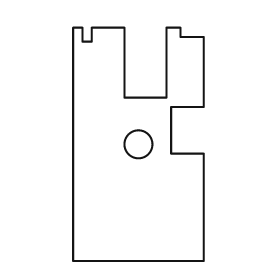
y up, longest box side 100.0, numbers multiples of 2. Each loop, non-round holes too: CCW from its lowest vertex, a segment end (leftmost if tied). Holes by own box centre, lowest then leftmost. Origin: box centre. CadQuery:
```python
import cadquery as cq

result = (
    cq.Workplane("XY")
    .moveTo(-28.0, -50.0)
    .lineTo(28.0, -50.0)
    .lineTo(28.0, -4.0)
    .lineTo(14.0, -4.0)
    .lineTo(14.0, 16.0)
    .lineTo(28.0, 16.0)
    .lineTo(28.0, 46.0)
    .lineTo(18.0, 46.0)
    .lineTo(18.0, 50.0)
    .lineTo(12.0, 50.0)
    .lineTo(12.0, 20.0)
    .lineTo(-6.0, 20.0)
    .lineTo(-6.0, 50.0)
    .lineTo(-20.0, 50.0)
    .lineTo(-20.0, 44.0)
    .lineTo(-24.0, 44.0)
    .lineTo(-24.0, 50.0)
    .lineTo(-28.0, 50.0)
    .close()
    .moveTo(0.0, 0.0)
    .circle(6.0)
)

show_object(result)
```